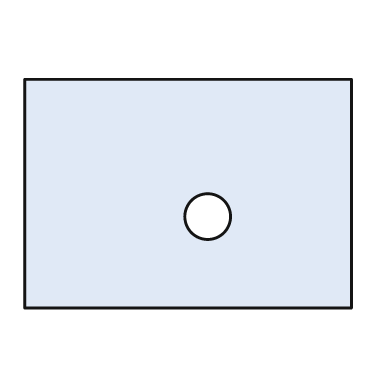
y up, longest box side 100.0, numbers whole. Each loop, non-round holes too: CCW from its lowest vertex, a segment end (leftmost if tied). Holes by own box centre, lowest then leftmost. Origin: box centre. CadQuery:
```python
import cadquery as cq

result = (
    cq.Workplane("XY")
    .moveTo(-50.0, -35.0)
    .lineTo(50.0, -35.0)
    .lineTo(50.0, 35.0)
    .lineTo(-50.0, 35.0)
    .close()
    .moveTo(6.0, -7.0)
    .circle(7.0)
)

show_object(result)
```